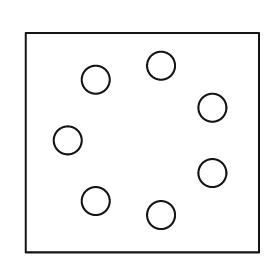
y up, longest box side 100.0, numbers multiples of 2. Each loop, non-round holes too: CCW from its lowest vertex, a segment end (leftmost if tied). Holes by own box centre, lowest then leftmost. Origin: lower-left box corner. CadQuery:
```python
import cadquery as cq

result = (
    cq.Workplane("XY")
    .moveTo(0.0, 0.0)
    .lineTo(100.0, 0.0)
    .lineTo(100.0, 94.0)
    .lineTo(0.0, 94.0)
    .close()
    .moveTo(58.0, 16.0)
    .circle(6.0)
    .moveTo(30.0, 22.0)
    .circle(6.0)
    .moveTo(80.0, 34.0)
    .circle(6.0)
    .moveTo(18.0, 48.0)
    .circle(6.0)
    .moveTo(80.0, 62.0)
    .circle(6.0)
    .moveTo(30.0, 74.0)
    .circle(6.0)
    .moveTo(58.0, 80.0)
    .circle(6.0)
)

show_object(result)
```